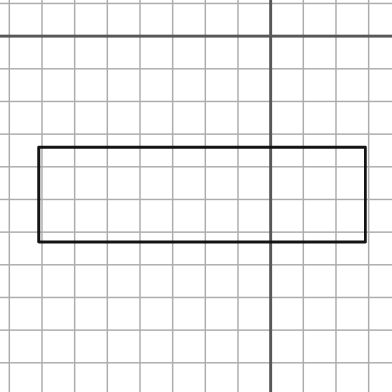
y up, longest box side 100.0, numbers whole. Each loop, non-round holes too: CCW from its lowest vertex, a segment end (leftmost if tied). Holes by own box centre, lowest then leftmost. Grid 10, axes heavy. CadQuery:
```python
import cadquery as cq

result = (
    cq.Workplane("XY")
    .moveTo(-71.0, -63.0)
    .lineTo(29.0, -63.0)
    .lineTo(29.0, -34.0)
    .lineTo(-71.0, -34.0)
    .close()
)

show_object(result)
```